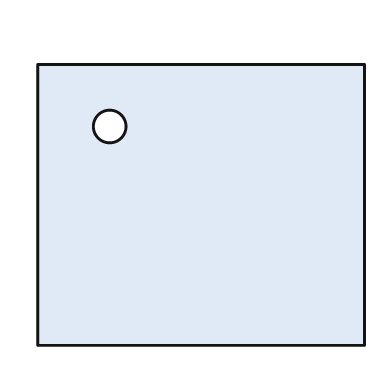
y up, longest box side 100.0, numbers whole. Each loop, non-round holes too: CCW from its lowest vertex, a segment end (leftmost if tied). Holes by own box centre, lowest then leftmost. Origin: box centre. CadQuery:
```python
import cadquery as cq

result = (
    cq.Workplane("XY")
    .moveTo(-50.0, -43.0)
    .lineTo(50.0, -43.0)
    .lineTo(50.0, 43.0)
    .lineTo(-50.0, 43.0)
    .close()
    .moveTo(-28.0, 24.0)
    .circle(5.0)
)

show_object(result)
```